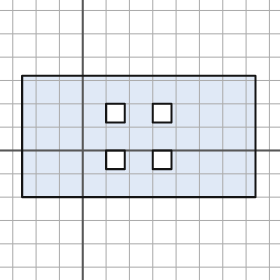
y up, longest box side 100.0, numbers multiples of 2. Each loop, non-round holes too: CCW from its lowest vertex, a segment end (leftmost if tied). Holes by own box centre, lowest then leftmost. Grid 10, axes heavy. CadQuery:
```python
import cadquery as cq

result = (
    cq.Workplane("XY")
    .moveTo(-26.0, -20.0)
    .lineTo(74.0, -20.0)
    .lineTo(74.0, 32.0)
    .lineTo(-26.0, 32.0)
    .close()
    .moveTo(10.0, -8.0)
    .lineTo(18.0, -8.0)
    .lineTo(18.0, 0.0)
    .lineTo(10.0, 0.0)
    .close()
    .moveTo(30.0, -8.0)
    .lineTo(38.0, -8.0)
    .lineTo(38.0, 0.0)
    .lineTo(30.0, 0.0)
    .close()
    .moveTo(10.0, 12.0)
    .lineTo(18.0, 12.0)
    .lineTo(18.0, 20.0)
    .lineTo(10.0, 20.0)
    .close()
    .moveTo(30.0, 12.0)
    .lineTo(38.0, 12.0)
    .lineTo(38.0, 20.0)
    .lineTo(30.0, 20.0)
    .close()
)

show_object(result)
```